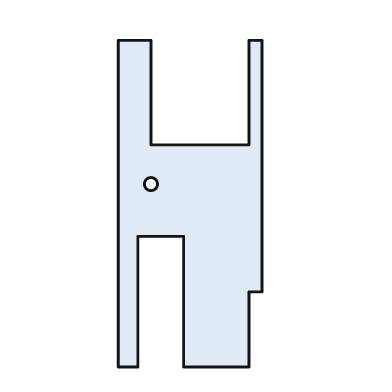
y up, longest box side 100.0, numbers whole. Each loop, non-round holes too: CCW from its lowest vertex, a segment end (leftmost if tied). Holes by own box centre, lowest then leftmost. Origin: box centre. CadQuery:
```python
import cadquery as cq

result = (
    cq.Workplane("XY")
    .moveTo(-22.0, -50.0)
    .lineTo(-16.0, -50.0)
    .lineTo(-16.0, -10.0)
    .lineTo(-2.0, -10.0)
    .lineTo(-2.0, -50.0)
    .lineTo(18.0, -50.0)
    .lineTo(18.0, -27.0)
    .lineTo(22.0, -27.0)
    .lineTo(22.0, 50.0)
    .lineTo(18.0, 50.0)
    .lineTo(18.0, 18.0)
    .lineTo(-12.0, 18.0)
    .lineTo(-12.0, 50.0)
    .lineTo(-22.0, 50.0)
    .close()
    .moveTo(-12.0, 6.0)
    .circle(2.0)
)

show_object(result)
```